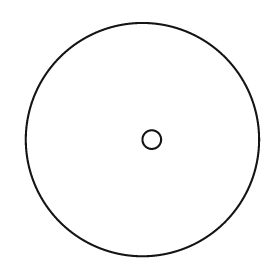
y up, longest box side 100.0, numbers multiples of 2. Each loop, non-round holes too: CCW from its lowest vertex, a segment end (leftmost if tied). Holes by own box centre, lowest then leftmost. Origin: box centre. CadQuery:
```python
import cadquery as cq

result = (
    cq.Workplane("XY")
    .moveTo(0.0, 0.0)
    .circle(50.0)
    .moveTo(4.0, 0.0)
    .circle(4.0)
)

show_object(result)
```